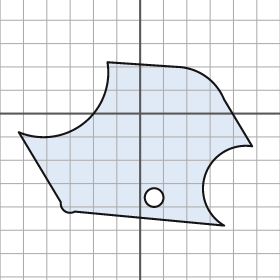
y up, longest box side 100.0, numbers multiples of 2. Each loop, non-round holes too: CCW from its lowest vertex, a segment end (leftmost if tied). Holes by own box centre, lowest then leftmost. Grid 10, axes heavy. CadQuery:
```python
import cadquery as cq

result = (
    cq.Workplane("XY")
    .moveTo(36.0, -48.0)
    .threePointArc((28.0, -26.0), (48.0, -14.0))
    .lineTo(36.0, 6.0)
    .threePointArc((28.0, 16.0), (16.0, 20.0))
    .lineTo(-14.0, 22.0)
    .threePointArc((-24.0, -4.0), (-52.0, -8.0))
    .lineTo(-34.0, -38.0)
    .threePointArc((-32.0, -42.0), (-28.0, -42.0))
    .close()
    .moveTo(6.0, -36.0)
    .circle(4.0)
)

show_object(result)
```